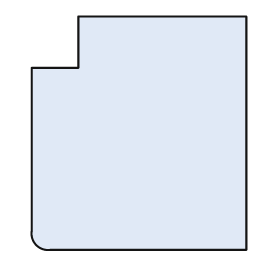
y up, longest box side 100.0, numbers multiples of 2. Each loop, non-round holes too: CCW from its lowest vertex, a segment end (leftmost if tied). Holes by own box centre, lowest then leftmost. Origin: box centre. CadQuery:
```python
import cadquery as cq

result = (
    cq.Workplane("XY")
    .moveTo(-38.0, -50.0)
    .lineTo(46.0, -50.0)
    .lineTo(46.0, 50.0)
    .lineTo(-26.0, 50.0)
    .lineTo(-26.0, 28.0)
    .lineTo(-46.0, 28.0)
    .lineTo(-46.0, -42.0)
    .threePointArc((-44.0, -48.0), (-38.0, -50.0))
    .close()
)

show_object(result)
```